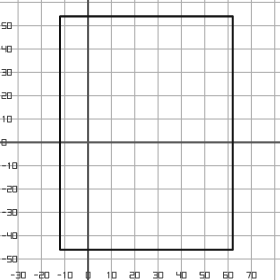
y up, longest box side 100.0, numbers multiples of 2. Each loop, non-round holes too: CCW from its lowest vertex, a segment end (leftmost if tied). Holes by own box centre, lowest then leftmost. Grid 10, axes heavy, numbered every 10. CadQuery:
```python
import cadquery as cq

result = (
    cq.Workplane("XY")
    .moveTo(-12.0, -46.0)
    .lineTo(62.0, -46.0)
    .lineTo(62.0, 54.0)
    .lineTo(-12.0, 54.0)
    .close()
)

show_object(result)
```